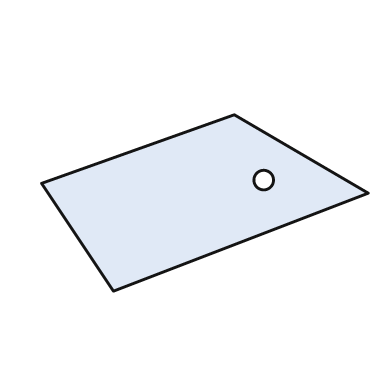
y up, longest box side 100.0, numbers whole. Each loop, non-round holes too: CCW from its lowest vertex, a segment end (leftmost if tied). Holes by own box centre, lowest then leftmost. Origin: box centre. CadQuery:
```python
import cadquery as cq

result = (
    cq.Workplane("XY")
    .moveTo(-28.0, -27.0)
    .lineTo(50.0, 3.0)
    .lineTo(9.0, 27.0)
    .lineTo(-50.0, 6.0)
    .close()
    .moveTo(18.0, 7.0)
    .circle(3.0)
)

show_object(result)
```